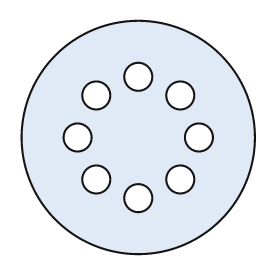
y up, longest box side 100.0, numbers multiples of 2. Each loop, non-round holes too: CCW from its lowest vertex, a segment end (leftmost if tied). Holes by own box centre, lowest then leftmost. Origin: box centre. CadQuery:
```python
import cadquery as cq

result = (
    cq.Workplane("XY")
    .moveTo(0.0, 0.0)
    .circle(50.0)
    .moveTo(0.0, -26.0)
    .circle(6.0)
    .moveTo(-18.0, -18.0)
    .circle(6.0)
    .moveTo(18.0, -18.0)
    .circle(6.0)
    .moveTo(-26.0, 0.0)
    .circle(6.0)
    .moveTo(26.0, 0.0)
    .circle(6.0)
    .moveTo(-18.0, 18.0)
    .circle(6.0)
    .moveTo(18.0, 18.0)
    .circle(6.0)
    .moveTo(0.0, 26.0)
    .circle(6.0)
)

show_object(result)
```